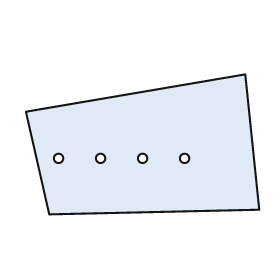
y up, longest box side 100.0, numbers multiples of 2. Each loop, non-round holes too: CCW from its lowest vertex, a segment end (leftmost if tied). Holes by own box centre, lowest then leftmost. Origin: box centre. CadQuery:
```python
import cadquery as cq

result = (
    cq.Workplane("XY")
    .moveTo(-40.0, -30.0)
    .lineTo(50.0, -28.0)
    .lineTo(44.0, 30.0)
    .lineTo(-50.0, 14.0)
    .close()
    .moveTo(-36.0, -6.0)
    .circle(2.0)
    .moveTo(-18.0, -6.0)
    .circle(2.0)
    .moveTo(0.0, -6.0)
    .circle(2.0)
    .moveTo(18.0, -6.0)
    .circle(2.0)
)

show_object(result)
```